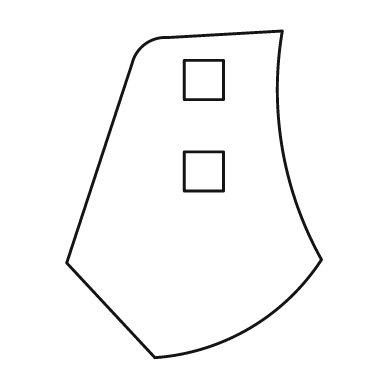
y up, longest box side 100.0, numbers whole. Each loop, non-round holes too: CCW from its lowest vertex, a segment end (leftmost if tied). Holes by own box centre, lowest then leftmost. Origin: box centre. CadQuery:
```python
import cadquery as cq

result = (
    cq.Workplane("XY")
    .moveTo(-12.0, -50.0)
    .threePointArc((17.0, -41.0), (39.0, -20.0))
    .threePointArc((27.0, 14.0), (27.0, 50.0))
    .lineTo(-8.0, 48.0)
    .threePointArc((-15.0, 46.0), (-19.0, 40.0))
    .lineTo(-39.0, -21.0)
    .close()
    .moveTo(-3.0, 1.0)
    .lineTo(9.0, 1.0)
    .lineTo(9.0, 13.0)
    .lineTo(-3.0, 13.0)
    .close()
    .moveTo(-3.0, 29.0)
    .lineTo(9.0, 29.0)
    .lineTo(9.0, 41.0)
    .lineTo(-3.0, 41.0)
    .close()
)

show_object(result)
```